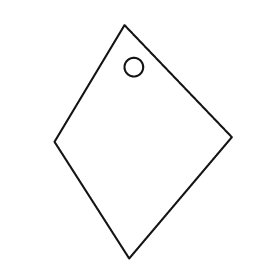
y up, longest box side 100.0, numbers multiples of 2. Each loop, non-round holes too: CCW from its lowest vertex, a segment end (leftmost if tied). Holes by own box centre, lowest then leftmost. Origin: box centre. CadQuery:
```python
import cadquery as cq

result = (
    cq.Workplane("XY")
    .moveTo(-6.0, -50.0)
    .lineTo(38.0, 2.0)
    .lineTo(-8.0, 50.0)
    .lineTo(-38.0, 0.0)
    .close()
    .moveTo(-4.0, 32.0)
    .circle(4.0)
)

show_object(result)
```